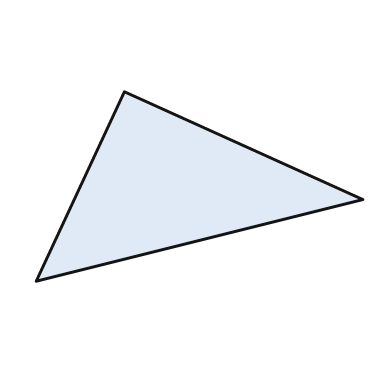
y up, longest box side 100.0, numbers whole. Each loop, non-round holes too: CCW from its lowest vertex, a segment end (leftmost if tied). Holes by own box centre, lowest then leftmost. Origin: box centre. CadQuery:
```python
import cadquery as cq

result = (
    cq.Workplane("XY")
    .moveTo(-50.0, -29.0)
    .lineTo(50.0, -4.0)
    .lineTo(-23.0, 29.0)
    .close()
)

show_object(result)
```